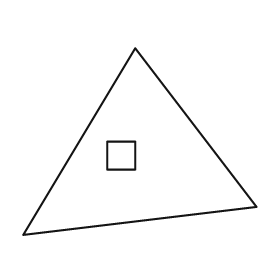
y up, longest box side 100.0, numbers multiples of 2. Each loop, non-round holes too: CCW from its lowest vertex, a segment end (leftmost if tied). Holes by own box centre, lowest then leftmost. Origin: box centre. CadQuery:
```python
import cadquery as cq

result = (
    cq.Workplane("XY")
    .moveTo(-50.0, -40.0)
    .lineTo(50.0, -28.0)
    .lineTo(-2.0, 40.0)
    .close()
    .moveTo(-14.0, -12.0)
    .lineTo(-2.0, -12.0)
    .lineTo(-2.0, 0.0)
    .lineTo(-14.0, 0.0)
    .close()
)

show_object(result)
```